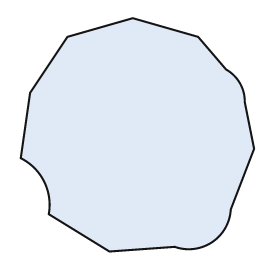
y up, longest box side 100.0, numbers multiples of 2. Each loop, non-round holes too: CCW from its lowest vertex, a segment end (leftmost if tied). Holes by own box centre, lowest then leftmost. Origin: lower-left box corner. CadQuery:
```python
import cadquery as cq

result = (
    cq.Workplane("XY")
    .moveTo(38.0, 0.0)
    .lineTo(66.0, 2.0)
    .threePointArc((82.0, 4.0), (90.0, 18.0))
    .lineTo(100.0, 44.0)
    .lineTo(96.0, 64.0)
    .threePointArc((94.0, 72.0), (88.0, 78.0))
    .lineTo(76.0, 92.0)
    .lineTo(48.0, 100.0)
    .lineTo(20.0, 92.0)
    .lineTo(4.0, 68.0)
    .lineTo(0.0, 40.0)
    .threePointArc((10.0, 30.0), (12.0, 16.0))
    .close()
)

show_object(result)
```